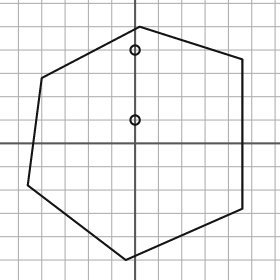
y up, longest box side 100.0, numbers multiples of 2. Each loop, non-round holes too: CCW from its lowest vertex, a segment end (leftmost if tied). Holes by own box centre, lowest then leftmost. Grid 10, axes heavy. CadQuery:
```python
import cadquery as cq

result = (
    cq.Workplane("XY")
    .moveTo(-4.0, -50.0)
    .lineTo(46.0, -28.0)
    .lineTo(46.0, 36.0)
    .lineTo(2.0, 50.0)
    .lineTo(-40.0, 28.0)
    .lineTo(-46.0, -18.0)
    .close()
    .moveTo(0.0, 10.0)
    .circle(2.0)
    .moveTo(0.0, 40.0)
    .circle(2.0)
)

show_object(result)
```